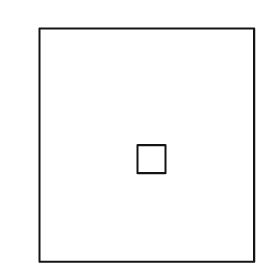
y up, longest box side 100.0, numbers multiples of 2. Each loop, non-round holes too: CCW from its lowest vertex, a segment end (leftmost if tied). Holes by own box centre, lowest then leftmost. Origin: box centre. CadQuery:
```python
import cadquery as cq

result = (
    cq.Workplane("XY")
    .moveTo(-46.0, -50.0)
    .lineTo(46.0, -50.0)
    .lineTo(46.0, 50.0)
    .lineTo(-46.0, 50.0)
    .close()
    .moveTo(-4.0, -12.0)
    .lineTo(8.0, -12.0)
    .lineTo(8.0, 0.0)
    .lineTo(-4.0, 0.0)
    .close()
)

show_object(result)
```